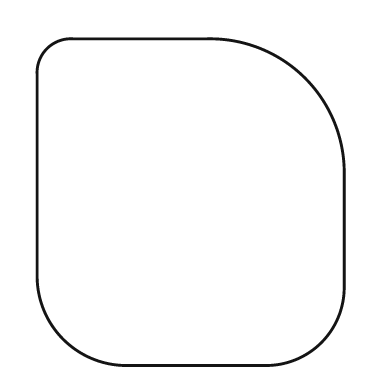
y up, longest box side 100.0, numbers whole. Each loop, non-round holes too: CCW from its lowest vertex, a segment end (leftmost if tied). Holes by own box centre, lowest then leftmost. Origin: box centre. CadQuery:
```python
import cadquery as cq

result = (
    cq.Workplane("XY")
    .moveTo(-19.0, -50.0)
    .lineTo(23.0, -50.0)
    .threePointArc((40.0, -43.0), (47.0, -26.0))
    .lineTo(47.0, 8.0)
    .threePointArc((35.0, 38.0), (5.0, 50.0))
    .lineTo(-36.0, 50.0)
    .threePointArc((-44.0, 47.0), (-47.0, 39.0))
    .lineTo(-47.0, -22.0)
    .threePointArc((-39.0, -42.0), (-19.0, -50.0))
    .close()
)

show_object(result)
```